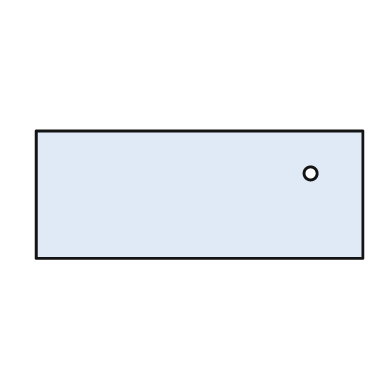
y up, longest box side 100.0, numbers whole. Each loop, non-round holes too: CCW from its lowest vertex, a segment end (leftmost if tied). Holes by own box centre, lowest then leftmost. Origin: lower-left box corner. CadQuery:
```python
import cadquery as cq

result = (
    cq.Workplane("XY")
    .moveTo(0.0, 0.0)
    .lineTo(100.0, 0.0)
    .lineTo(100.0, 39.0)
    .lineTo(0.0, 39.0)
    .close()
    .moveTo(84.0, 26.0)
    .circle(2.0)
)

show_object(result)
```